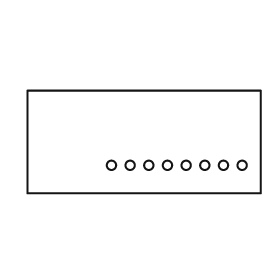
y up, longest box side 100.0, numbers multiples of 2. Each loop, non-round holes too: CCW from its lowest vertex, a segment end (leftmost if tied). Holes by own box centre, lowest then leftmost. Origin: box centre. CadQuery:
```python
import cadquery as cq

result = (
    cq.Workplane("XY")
    .moveTo(-50.0, -22.0)
    .lineTo(50.0, -22.0)
    .lineTo(50.0, 22.0)
    .lineTo(-50.0, 22.0)
    .close()
    .moveTo(-14.0, -10.0)
    .circle(2.0)
    .moveTo(-6.0, -10.0)
    .circle(2.0)
    .moveTo(2.0, -10.0)
    .circle(2.0)
    .moveTo(10.0, -10.0)
    .circle(2.0)
    .moveTo(18.0, -10.0)
    .circle(2.0)
    .moveTo(26.0, -10.0)
    .circle(2.0)
    .moveTo(34.0, -10.0)
    .circle(2.0)
    .moveTo(42.0, -10.0)
    .circle(2.0)
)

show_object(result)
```